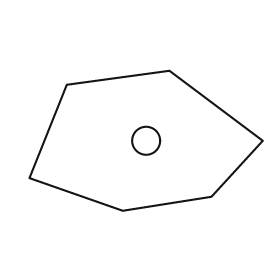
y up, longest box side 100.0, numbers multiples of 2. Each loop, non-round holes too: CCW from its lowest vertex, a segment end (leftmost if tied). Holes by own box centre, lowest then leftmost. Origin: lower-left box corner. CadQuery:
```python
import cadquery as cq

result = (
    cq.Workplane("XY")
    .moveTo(40.0, 0.0)
    .lineTo(78.0, 6.0)
    .lineTo(100.0, 30.0)
    .lineTo(60.0, 60.0)
    .lineTo(16.0, 54.0)
    .lineTo(0.0, 14.0)
    .close()
    .moveTo(50.0, 30.0)
    .circle(6.0)
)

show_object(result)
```